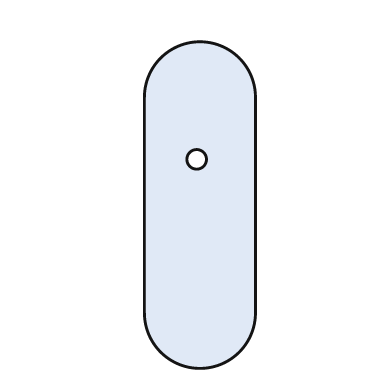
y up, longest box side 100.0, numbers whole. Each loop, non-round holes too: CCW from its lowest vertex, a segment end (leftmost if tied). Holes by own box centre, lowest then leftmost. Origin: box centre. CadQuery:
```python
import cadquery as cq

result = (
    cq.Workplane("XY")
    .moveTo(-17.0, -33.0)
    .threePointArc((0.0, -50.0), (17.0, -33.0))
    .lineTo(17.0, 33.0)
    .threePointArc((0.0, 50.0), (-17.0, 33.0))
    .close()
    .moveTo(-1.0, 14.0)
    .circle(3.0)
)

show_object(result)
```